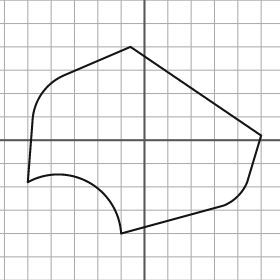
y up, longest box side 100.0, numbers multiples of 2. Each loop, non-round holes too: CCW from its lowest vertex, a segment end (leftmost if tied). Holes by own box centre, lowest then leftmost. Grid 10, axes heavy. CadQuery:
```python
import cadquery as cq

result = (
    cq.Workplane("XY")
    .moveTo(-10.0, -40.0)
    .lineTo(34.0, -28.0)
    .threePointArc((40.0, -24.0), (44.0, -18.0))
    .lineTo(50.0, 2.0)
    .lineTo(-6.0, 40.0)
    .lineTo(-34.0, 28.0)
    .threePointArc((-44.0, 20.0), (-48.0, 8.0))
    .lineTo(-50.0, -18.0)
    .threePointArc((-24.0, -18.0), (-10.0, -40.0))
    .close()
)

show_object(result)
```